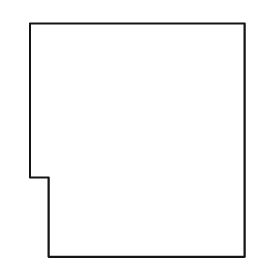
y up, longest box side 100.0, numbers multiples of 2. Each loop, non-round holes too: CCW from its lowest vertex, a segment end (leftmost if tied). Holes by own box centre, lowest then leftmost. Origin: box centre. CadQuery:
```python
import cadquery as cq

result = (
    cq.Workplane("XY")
    .moveTo(-38.0, -50.0)
    .lineTo(46.0, -50.0)
    .lineTo(46.0, 50.0)
    .lineTo(-46.0, 50.0)
    .lineTo(-46.0, -16.0)
    .lineTo(-38.0, -16.0)
    .close()
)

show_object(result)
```